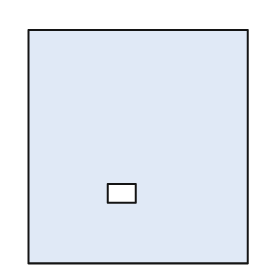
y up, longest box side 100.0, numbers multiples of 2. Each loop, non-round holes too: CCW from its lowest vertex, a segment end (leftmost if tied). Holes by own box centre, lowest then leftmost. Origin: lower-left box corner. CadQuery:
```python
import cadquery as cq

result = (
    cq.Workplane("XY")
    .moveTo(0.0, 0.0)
    .lineTo(94.0, 0.0)
    .lineTo(94.0, 100.0)
    .lineTo(0.0, 100.0)
    .close()
    .moveTo(34.0, 26.0)
    .lineTo(46.0, 26.0)
    .lineTo(46.0, 34.0)
    .lineTo(34.0, 34.0)
    .close()
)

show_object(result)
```